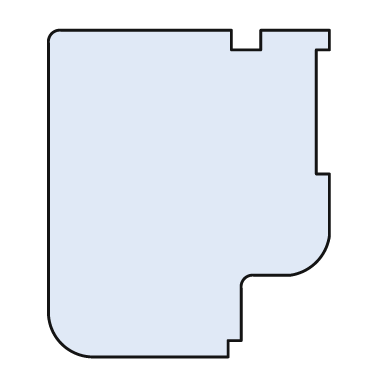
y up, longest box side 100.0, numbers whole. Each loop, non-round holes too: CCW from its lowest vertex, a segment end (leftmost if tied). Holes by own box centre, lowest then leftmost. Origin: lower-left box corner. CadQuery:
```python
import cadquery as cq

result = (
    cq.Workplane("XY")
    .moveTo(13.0, 0.0)
    .lineTo(55.0, 0.0)
    .lineTo(55.0, 5.0)
    .lineTo(59.0, 5.0)
    .lineTo(59.0, 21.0)
    .threePointArc((60.0, 24.0), (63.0, 25.0))
    .lineTo(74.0, 25.0)
    .threePointArc((82.0, 29.0), (86.0, 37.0))
    .lineTo(86.0, 56.0)
    .lineTo(82.0, 56.0)
    .lineTo(82.0, 94.0)
    .lineTo(86.0, 94.0)
    .lineTo(86.0, 100.0)
    .lineTo(65.0, 100.0)
    .lineTo(65.0, 94.0)
    .lineTo(56.0, 94.0)
    .lineTo(56.0, 100.0)
    .lineTo(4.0, 100.0)
    .threePointArc((1.0, 99.0), (0.0, 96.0))
    .lineTo(0.0, 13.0)
    .threePointArc((4.0, 4.0), (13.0, 0.0))
    .close()
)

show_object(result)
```